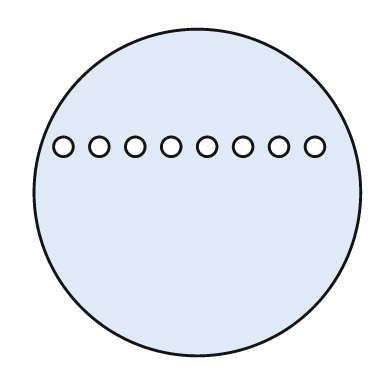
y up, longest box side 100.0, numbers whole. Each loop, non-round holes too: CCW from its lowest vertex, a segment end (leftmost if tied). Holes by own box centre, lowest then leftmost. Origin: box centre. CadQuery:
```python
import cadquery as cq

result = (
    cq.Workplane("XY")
    .moveTo(0.0, 0.0)
    .circle(50.0)
    .moveTo(-41.0, 14.0)
    .circle(3.0)
    .moveTo(-30.0, 14.0)
    .circle(3.0)
    .moveTo(-19.0, 14.0)
    .circle(3.0)
    .moveTo(-8.0, 14.0)
    .circle(3.0)
    .moveTo(3.0, 14.0)
    .circle(3.0)
    .moveTo(14.0, 14.0)
    .circle(3.0)
    .moveTo(25.0, 14.0)
    .circle(3.0)
    .moveTo(36.0, 14.0)
    .circle(3.0)
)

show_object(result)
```